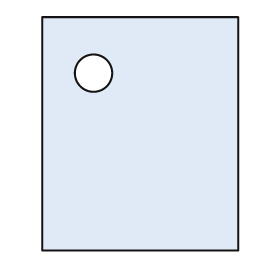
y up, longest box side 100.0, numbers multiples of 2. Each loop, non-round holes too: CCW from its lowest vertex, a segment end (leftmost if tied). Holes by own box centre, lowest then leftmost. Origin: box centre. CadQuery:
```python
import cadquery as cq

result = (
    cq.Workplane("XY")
    .moveTo(-42.0, -50.0)
    .lineTo(42.0, -50.0)
    .lineTo(42.0, 50.0)
    .lineTo(-42.0, 50.0)
    .close()
    .moveTo(-20.0, 26.0)
    .circle(8.0)
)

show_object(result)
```